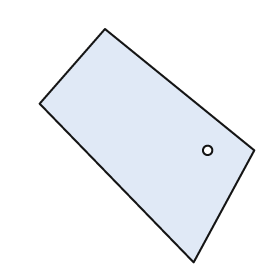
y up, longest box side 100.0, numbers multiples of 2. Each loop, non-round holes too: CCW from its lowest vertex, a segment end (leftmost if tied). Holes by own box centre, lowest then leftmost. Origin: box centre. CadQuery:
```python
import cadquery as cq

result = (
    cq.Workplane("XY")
    .moveTo(20.0, -50.0)
    .lineTo(46.0, -2.0)
    .lineTo(-18.0, 50.0)
    .lineTo(-46.0, 18.0)
    .close()
    .moveTo(26.0, -2.0)
    .circle(2.0)
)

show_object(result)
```